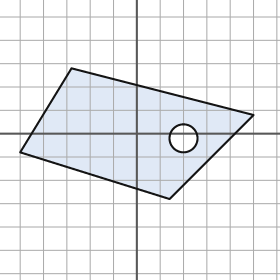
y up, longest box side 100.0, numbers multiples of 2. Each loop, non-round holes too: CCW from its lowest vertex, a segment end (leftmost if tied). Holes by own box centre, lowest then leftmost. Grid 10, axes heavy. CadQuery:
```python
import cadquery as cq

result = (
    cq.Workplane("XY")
    .moveTo(14.0, -28.0)
    .lineTo(50.0, 8.0)
    .lineTo(-28.0, 28.0)
    .lineTo(-50.0, -8.0)
    .close()
    .moveTo(20.0, -2.0)
    .circle(6.0)
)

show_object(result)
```